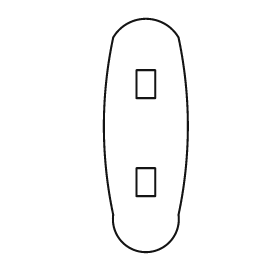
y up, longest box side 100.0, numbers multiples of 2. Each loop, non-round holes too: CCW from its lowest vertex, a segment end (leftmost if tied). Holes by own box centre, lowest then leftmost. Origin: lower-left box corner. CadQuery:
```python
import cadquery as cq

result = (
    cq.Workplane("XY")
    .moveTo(4.0, 16.0)
    .threePointArc((18.0, 0.0), (32.0, 16.0))
    .threePointArc((36.0, 54.0), (32.0, 92.0))
    .threePointArc((18.0, 100.0), (4.0, 92.0))
    .threePointArc((0.0, 54.0), (4.0, 16.0))
    .close()
    .moveTo(14.0, 24.0)
    .lineTo(22.0, 24.0)
    .lineTo(22.0, 36.0)
    .lineTo(14.0, 36.0)
    .close()
    .moveTo(14.0, 66.0)
    .lineTo(22.0, 66.0)
    .lineTo(22.0, 78.0)
    .lineTo(14.0, 78.0)
    .close()
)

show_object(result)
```